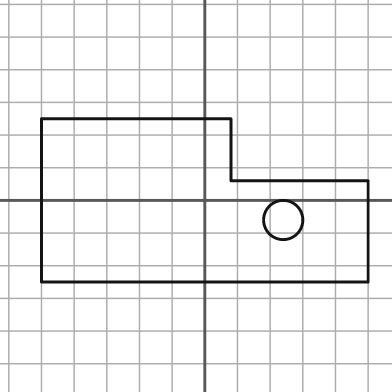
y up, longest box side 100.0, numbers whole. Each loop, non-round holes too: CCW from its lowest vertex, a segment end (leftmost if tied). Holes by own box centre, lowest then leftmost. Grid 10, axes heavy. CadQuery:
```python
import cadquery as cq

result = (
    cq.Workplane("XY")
    .moveTo(-50.0, -25.0)
    .lineTo(50.0, -25.0)
    .lineTo(50.0, 6.0)
    .lineTo(8.0, 6.0)
    .lineTo(8.0, 25.0)
    .lineTo(-50.0, 25.0)
    .close()
    .moveTo(24.0, -6.0)
    .circle(6.0)
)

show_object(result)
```